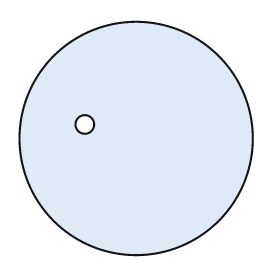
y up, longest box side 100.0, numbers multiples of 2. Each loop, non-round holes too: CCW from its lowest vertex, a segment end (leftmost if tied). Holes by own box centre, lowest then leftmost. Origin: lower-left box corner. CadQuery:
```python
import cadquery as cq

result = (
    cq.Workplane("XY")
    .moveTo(50.0, 50.0)
    .circle(50.0)
    .moveTo(28.0, 56.0)
    .circle(4.0)
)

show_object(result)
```